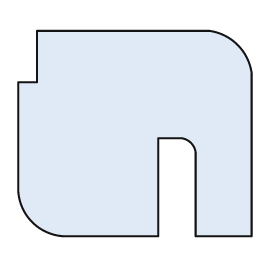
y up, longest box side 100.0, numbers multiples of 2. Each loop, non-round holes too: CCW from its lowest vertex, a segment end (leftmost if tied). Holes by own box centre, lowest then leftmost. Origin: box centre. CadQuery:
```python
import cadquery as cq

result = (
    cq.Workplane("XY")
    .moveTo(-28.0, -44.0)
    .lineTo(10.0, -44.0)
    .lineTo(10.0, -2.0)
    .lineTo(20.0, -2.0)
    .threePointArc((24.0, -4.0), (26.0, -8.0))
    .lineTo(26.0, -44.0)
    .lineTo(50.0, -44.0)
    .lineTo(50.0, 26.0)
    .threePointArc((44.0, 38.0), (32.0, 44.0))
    .lineTo(-42.0, 44.0)
    .lineTo(-42.0, 22.0)
    .lineTo(-50.0, 22.0)
    .lineTo(-50.0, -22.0)
    .threePointArc((-44.0, -38.0), (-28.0, -44.0))
    .close()
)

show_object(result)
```